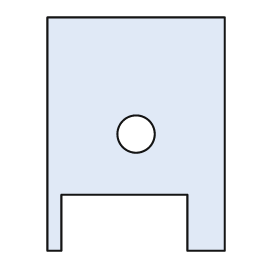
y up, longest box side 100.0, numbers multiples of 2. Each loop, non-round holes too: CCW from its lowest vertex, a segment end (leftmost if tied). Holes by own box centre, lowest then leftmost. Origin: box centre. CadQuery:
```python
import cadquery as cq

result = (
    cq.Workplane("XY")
    .moveTo(-38.0, -50.0)
    .lineTo(-32.0, -50.0)
    .lineTo(-32.0, -26.0)
    .lineTo(22.0, -26.0)
    .lineTo(22.0, -50.0)
    .lineTo(38.0, -50.0)
    .lineTo(38.0, 50.0)
    .lineTo(-38.0, 50.0)
    .close()
    .moveTo(0.0, 0.0)
    .circle(8.0)
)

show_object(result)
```